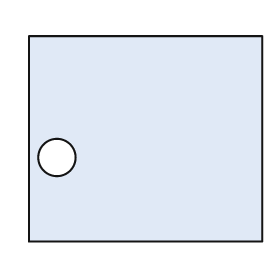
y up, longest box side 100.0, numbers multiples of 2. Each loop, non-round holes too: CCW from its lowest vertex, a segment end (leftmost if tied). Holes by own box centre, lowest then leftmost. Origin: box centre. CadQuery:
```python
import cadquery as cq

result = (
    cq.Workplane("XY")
    .moveTo(-50.0, -44.0)
    .lineTo(50.0, -44.0)
    .lineTo(50.0, 44.0)
    .lineTo(-50.0, 44.0)
    .close()
    .moveTo(-38.0, -8.0)
    .circle(8.0)
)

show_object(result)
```